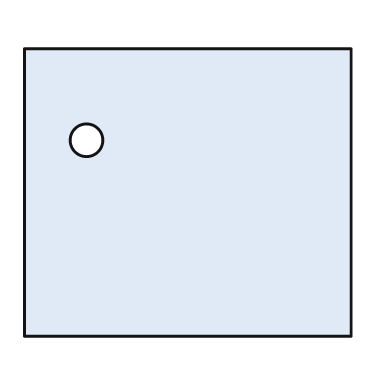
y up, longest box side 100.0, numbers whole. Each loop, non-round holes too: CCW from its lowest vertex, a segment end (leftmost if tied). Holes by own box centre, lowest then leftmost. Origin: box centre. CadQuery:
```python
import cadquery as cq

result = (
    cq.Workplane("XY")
    .moveTo(-50.0, -44.0)
    .lineTo(50.0, -44.0)
    .lineTo(50.0, 44.0)
    .lineTo(-50.0, 44.0)
    .close()
    .moveTo(-31.0, 16.0)
    .circle(5.0)
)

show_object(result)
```